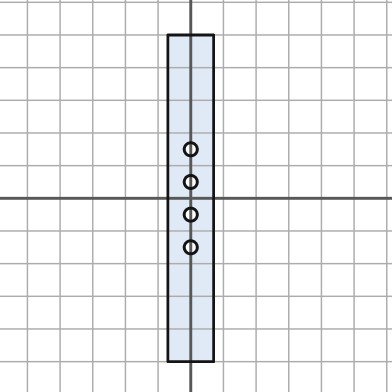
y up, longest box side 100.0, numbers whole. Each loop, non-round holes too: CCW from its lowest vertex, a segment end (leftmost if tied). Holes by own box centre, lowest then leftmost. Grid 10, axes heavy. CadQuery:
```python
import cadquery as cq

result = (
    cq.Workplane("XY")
    .moveTo(-7.0, -50.0)
    .lineTo(7.0, -50.0)
    .lineTo(7.0, 50.0)
    .lineTo(-7.0, 50.0)
    .close()
    .moveTo(0.0, -15.0)
    .circle(2.0)
    .moveTo(0.0, -5.0)
    .circle(2.0)
    .moveTo(0.0, 5.0)
    .circle(2.0)
    .moveTo(0.0, 15.0)
    .circle(2.0)
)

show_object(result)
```